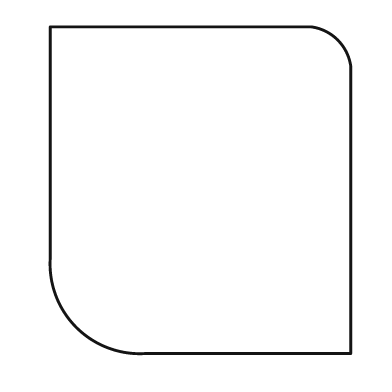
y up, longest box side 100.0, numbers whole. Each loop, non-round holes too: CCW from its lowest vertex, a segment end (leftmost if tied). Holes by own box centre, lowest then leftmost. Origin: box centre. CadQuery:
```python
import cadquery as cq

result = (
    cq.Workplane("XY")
    .moveTo(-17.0, -50.0)
    .lineTo(46.0, -50.0)
    .lineTo(46.0, 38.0)
    .threePointArc((42.0, 46.0), (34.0, 50.0))
    .lineTo(-46.0, 50.0)
    .lineTo(-46.0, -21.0)
    .threePointArc((-38.0, -42.0), (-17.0, -50.0))
    .close()
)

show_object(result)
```